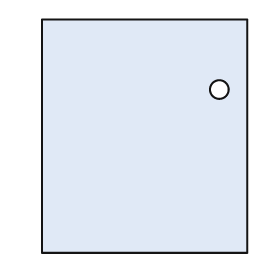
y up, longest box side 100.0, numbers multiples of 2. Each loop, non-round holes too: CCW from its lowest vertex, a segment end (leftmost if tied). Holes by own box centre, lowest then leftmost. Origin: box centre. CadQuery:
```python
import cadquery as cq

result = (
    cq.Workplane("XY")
    .moveTo(-44.0, -50.0)
    .lineTo(44.0, -50.0)
    .lineTo(44.0, 50.0)
    .lineTo(-44.0, 50.0)
    .close()
    .moveTo(32.0, 20.0)
    .circle(4.0)
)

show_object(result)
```